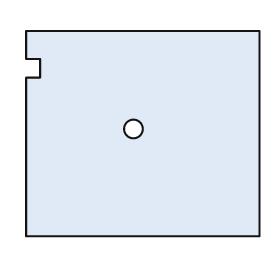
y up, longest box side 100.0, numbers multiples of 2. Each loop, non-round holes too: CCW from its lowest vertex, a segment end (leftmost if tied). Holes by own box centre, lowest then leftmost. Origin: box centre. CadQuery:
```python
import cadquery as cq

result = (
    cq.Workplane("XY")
    .moveTo(-50.0, -44.0)
    .lineTo(50.0, -44.0)
    .lineTo(50.0, 44.0)
    .lineTo(-50.0, 44.0)
    .lineTo(-50.0, 32.0)
    .lineTo(-44.0, 32.0)
    .lineTo(-44.0, 24.0)
    .lineTo(-50.0, 24.0)
    .close()
    .moveTo(-4.0, 2.0)
    .circle(4.0)
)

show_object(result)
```